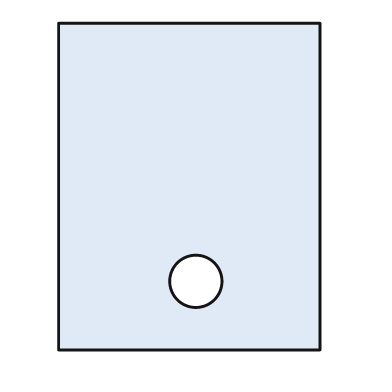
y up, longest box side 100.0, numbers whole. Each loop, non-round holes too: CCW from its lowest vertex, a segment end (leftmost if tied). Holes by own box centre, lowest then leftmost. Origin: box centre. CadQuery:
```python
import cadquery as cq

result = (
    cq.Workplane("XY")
    .moveTo(-40.0, -50.0)
    .lineTo(40.0, -50.0)
    .lineTo(40.0, 50.0)
    .lineTo(-40.0, 50.0)
    .close()
    .moveTo(2.0, -29.0)
    .circle(8.0)
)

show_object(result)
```